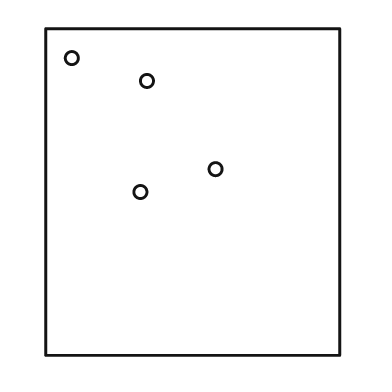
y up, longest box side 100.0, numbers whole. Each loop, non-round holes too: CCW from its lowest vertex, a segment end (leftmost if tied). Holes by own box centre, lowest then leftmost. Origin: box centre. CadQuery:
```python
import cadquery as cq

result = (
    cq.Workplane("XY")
    .moveTo(-45.0, -50.0)
    .lineTo(45.0, -50.0)
    .lineTo(45.0, 50.0)
    .lineTo(-45.0, 50.0)
    .close()
    .moveTo(-16.0, 0.0)
    .circle(2.0)
    .moveTo(7.0, 7.0)
    .circle(2.0)
    .moveTo(-14.0, 34.0)
    .circle(2.0)
    .moveTo(-37.0, 41.0)
    .circle(2.0)
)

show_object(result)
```